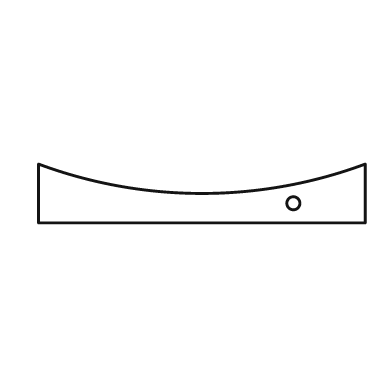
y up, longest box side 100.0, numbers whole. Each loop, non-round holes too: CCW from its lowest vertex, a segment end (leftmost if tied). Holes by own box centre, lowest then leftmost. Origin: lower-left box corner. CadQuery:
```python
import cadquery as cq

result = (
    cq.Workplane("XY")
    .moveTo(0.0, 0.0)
    .lineTo(100.0, 0.0)
    .lineTo(100.0, 18.0)
    .threePointArc((50.0, 9.0), (0.0, 18.0))
    .close()
    .moveTo(78.0, 6.0)
    .circle(2.0)
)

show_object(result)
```